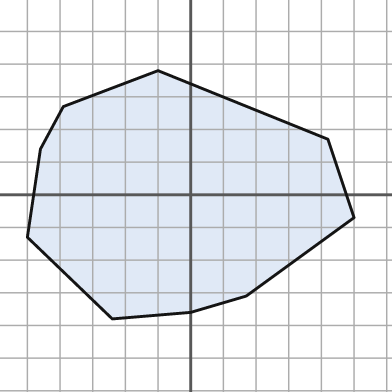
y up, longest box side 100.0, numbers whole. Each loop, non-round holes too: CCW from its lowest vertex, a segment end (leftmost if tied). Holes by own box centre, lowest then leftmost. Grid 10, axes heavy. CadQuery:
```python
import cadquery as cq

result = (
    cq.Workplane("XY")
    .moveTo(-24.0, -38.0)
    .lineTo(0.0, -36.0)
    .lineTo(17.0, -31.0)
    .lineTo(50.0, -7.0)
    .lineTo(42.0, 17.0)
    .lineTo(-10.0, 38.0)
    .lineTo(-39.0, 27.0)
    .lineTo(-46.0, 14.0)
    .lineTo(-50.0, -13.0)
    .close()
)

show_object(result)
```